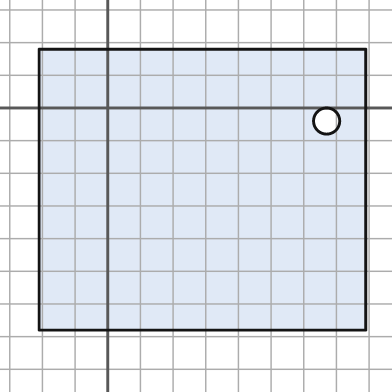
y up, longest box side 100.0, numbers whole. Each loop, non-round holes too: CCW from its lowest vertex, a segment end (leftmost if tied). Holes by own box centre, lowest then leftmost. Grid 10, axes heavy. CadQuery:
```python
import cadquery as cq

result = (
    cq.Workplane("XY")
    .moveTo(-21.0, -68.0)
    .lineTo(79.0, -68.0)
    .lineTo(79.0, 18.0)
    .lineTo(-21.0, 18.0)
    .close()
    .moveTo(67.0, -4.0)
    .circle(4.0)
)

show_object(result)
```